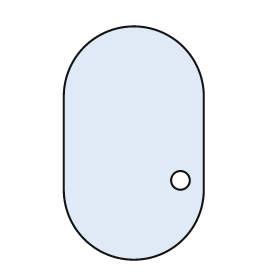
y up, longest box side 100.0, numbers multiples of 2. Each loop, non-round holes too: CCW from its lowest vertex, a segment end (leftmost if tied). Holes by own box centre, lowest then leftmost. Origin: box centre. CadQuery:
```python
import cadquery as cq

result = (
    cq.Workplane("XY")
    .moveTo(-30.0, -20.0)
    .threePointArc((0.0, -50.0), (30.0, -20.0))
    .lineTo(30.0, 20.0)
    .threePointArc((0.0, 50.0), (-30.0, 20.0))
    .close()
    .moveTo(20.0, -16.0)
    .circle(4.0)
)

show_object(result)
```